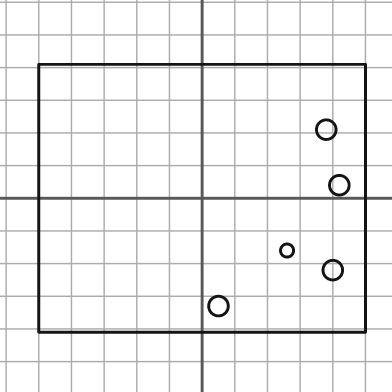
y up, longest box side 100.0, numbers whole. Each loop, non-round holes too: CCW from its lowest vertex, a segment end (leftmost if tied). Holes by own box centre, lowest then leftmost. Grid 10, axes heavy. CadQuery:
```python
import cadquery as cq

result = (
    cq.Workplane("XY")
    .moveTo(-50.0, -41.0)
    .lineTo(50.0, -41.0)
    .lineTo(50.0, 41.0)
    .lineTo(-50.0, 41.0)
    .close()
    .moveTo(5.0, -33.0)
    .circle(3.0)
    .moveTo(40.0, -22.0)
    .circle(3.0)
    .moveTo(26.0, -16.0)
    .circle(2.0)
    .moveTo(42.0, 4.0)
    .circle(3.0)
    .moveTo(38.0, 21.0)
    .circle(3.0)
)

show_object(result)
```